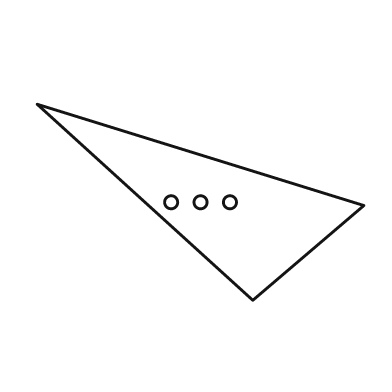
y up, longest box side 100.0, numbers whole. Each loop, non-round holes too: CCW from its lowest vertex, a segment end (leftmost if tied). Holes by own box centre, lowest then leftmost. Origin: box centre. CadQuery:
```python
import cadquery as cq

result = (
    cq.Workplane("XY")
    .moveTo(16.0, -30.0)
    .lineTo(50.0, -1.0)
    .lineTo(-50.0, 30.0)
    .close()
    .moveTo(-9.0, 0.0)
    .circle(2.0)
    .moveTo(0.0, 0.0)
    .circle(2.0)
    .moveTo(9.0, 0.0)
    .circle(2.0)
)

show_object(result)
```